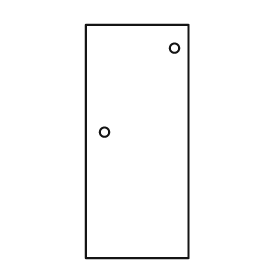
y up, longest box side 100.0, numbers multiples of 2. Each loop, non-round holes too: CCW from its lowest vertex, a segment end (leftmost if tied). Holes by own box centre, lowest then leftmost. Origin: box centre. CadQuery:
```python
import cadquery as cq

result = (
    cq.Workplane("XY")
    .moveTo(-22.0, -50.0)
    .lineTo(22.0, -50.0)
    .lineTo(22.0, 50.0)
    .lineTo(-22.0, 50.0)
    .close()
    .moveTo(-14.0, 4.0)
    .circle(2.0)
    .moveTo(16.0, 40.0)
    .circle(2.0)
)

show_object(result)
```